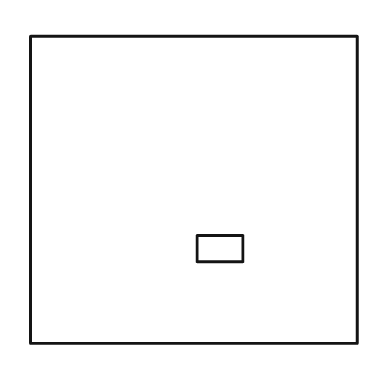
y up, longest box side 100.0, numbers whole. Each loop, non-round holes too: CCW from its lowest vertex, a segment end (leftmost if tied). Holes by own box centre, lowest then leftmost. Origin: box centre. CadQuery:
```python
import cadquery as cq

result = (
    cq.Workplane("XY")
    .moveTo(-50.0, -47.0)
    .lineTo(50.0, -47.0)
    .lineTo(50.0, 47.0)
    .lineTo(-50.0, 47.0)
    .close()
    .moveTo(1.0, -22.0)
    .lineTo(15.0, -22.0)
    .lineTo(15.0, -14.0)
    .lineTo(1.0, -14.0)
    .close()
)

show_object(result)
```